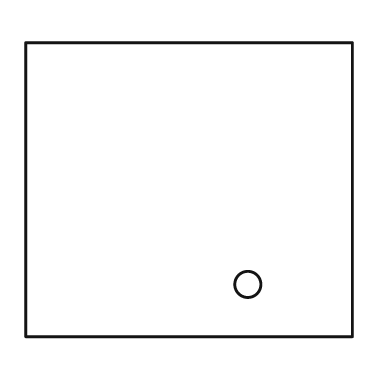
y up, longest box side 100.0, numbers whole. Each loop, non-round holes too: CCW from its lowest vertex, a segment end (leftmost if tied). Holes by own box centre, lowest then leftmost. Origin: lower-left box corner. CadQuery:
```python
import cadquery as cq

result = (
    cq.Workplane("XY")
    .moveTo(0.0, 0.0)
    .lineTo(100.0, 0.0)
    .lineTo(100.0, 90.0)
    .lineTo(0.0, 90.0)
    .close()
    .moveTo(68.0, 16.0)
    .circle(4.0)
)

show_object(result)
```